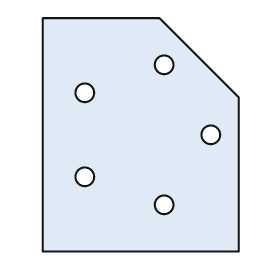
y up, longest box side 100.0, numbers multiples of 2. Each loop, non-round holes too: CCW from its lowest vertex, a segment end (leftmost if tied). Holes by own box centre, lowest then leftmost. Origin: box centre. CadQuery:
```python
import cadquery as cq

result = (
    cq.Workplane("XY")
    .moveTo(-42.0, -50.0)
    .lineTo(42.0, -50.0)
    .lineTo(42.0, 16.0)
    .lineTo(8.0, 50.0)
    .lineTo(-42.0, 50.0)
    .close()
    .moveTo(10.0, -30.0)
    .circle(4.0)
    .moveTo(-24.0, -18.0)
    .circle(4.0)
    .moveTo(30.0, 0.0)
    .circle(4.0)
    .moveTo(-24.0, 18.0)
    .circle(4.0)
    .moveTo(10.0, 30.0)
    .circle(4.0)
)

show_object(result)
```